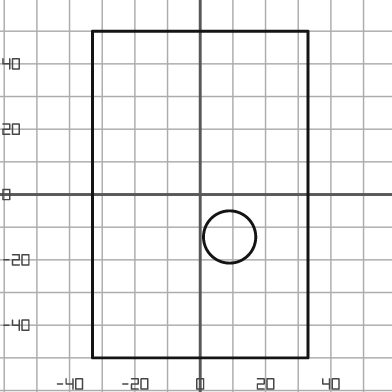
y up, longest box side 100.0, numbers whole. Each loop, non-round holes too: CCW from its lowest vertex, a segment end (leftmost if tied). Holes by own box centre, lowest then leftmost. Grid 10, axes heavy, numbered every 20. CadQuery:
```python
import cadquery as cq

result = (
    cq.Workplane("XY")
    .moveTo(-33.0, -50.0)
    .lineTo(33.0, -50.0)
    .lineTo(33.0, 50.0)
    .lineTo(-33.0, 50.0)
    .close()
    .moveTo(9.0, -13.0)
    .circle(8.0)
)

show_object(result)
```